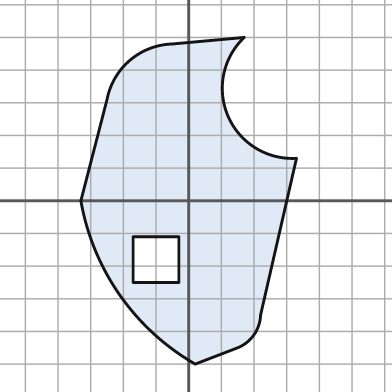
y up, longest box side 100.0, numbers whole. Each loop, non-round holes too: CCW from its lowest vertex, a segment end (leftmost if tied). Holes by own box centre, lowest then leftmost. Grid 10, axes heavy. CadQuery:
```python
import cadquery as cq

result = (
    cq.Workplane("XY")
    .moveTo(2.0, -50.0)
    .lineTo(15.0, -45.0)
    .threePointArc((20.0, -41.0), (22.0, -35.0))
    .lineTo(33.0, 13.0)
    .threePointArc((12.0, 26.0), (17.0, 50.0))
    .lineTo(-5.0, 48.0)
    .threePointArc((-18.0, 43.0), (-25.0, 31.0))
    .lineTo(-33.0, 0.0)
    .threePointArc((-21.0, -29.0), (2.0, -50.0))
    .close()
    .moveTo(-17.0, -25.0)
    .lineTo(-3.0, -25.0)
    .lineTo(-3.0, -11.0)
    .lineTo(-17.0, -11.0)
    .close()
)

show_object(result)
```